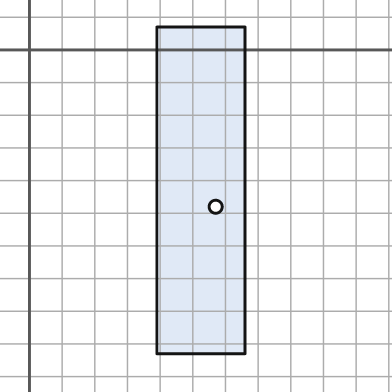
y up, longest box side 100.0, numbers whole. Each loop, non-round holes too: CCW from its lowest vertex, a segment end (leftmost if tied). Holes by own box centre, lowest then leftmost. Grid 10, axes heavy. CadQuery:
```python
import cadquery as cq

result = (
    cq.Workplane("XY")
    .moveTo(39.0, -93.0)
    .lineTo(66.0, -93.0)
    .lineTo(66.0, 7.0)
    .lineTo(39.0, 7.0)
    .close()
    .moveTo(57.0, -48.0)
    .circle(2.0)
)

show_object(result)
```